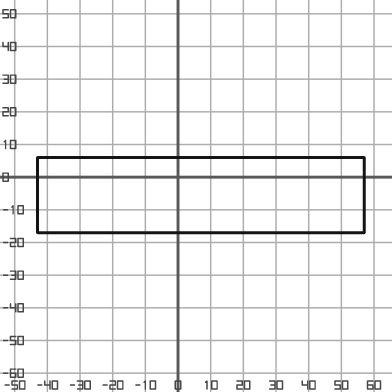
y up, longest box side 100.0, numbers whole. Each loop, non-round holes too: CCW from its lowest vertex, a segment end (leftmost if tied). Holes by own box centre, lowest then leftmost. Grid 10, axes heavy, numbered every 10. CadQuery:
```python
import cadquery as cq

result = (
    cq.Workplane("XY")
    .moveTo(-43.0, -17.0)
    .lineTo(57.0, -17.0)
    .lineTo(57.0, 6.0)
    .lineTo(-43.0, 6.0)
    .close()
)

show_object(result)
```